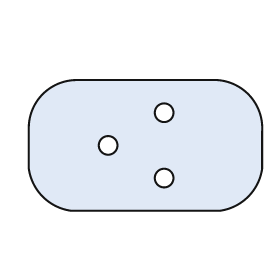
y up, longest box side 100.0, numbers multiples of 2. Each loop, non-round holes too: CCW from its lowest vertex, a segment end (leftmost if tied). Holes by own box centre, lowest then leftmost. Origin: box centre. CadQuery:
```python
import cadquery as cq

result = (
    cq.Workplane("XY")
    .moveTo(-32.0, -28.0)
    .lineTo(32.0, -28.0)
    .threePointArc((44.0, -22.0), (50.0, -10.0))
    .lineTo(50.0, 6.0)
    .threePointArc((44.0, 22.0), (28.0, 28.0))
    .lineTo(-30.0, 28.0)
    .threePointArc((-44.0, 22.0), (-50.0, 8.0))
    .lineTo(-50.0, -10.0)
    .threePointArc((-44.0, -22.0), (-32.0, -28.0))
    .close()
    .moveTo(8.0, -14.0)
    .circle(4.0)
    .moveTo(-16.0, 0.0)
    .circle(4.0)
    .moveTo(8.0, 14.0)
    .circle(4.0)
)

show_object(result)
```